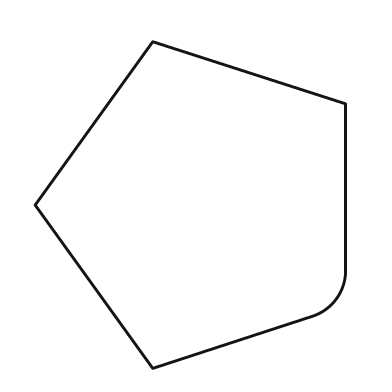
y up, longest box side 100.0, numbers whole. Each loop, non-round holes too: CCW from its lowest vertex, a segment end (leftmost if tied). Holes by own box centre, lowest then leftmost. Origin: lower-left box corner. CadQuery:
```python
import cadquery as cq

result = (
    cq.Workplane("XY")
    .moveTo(36.0, 0.0)
    .lineTo(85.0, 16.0)
    .threePointArc((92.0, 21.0), (95.0, 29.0))
    .lineTo(95.0, 81.0)
    .lineTo(36.0, 100.0)
    .lineTo(0.0, 50.0)
    .close()
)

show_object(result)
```